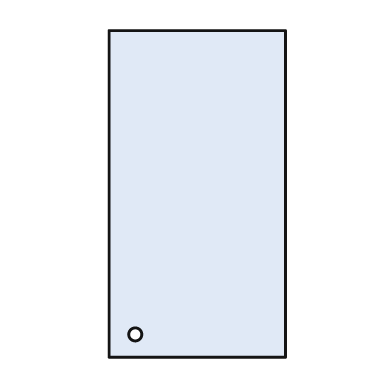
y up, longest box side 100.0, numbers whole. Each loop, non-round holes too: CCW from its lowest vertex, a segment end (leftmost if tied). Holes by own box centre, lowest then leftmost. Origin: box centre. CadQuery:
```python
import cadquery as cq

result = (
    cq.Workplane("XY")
    .moveTo(-27.0, -50.0)
    .lineTo(27.0, -50.0)
    .lineTo(27.0, 50.0)
    .lineTo(-27.0, 50.0)
    .close()
    .moveTo(-19.0, -43.0)
    .circle(2.0)
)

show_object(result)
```